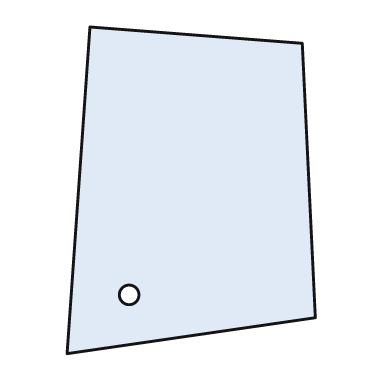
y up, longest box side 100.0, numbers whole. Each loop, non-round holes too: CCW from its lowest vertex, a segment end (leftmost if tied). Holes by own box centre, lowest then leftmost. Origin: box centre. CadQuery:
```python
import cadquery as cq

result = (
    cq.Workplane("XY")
    .moveTo(-38.0, -50.0)
    .lineTo(38.0, -39.0)
    .lineTo(34.0, 45.0)
    .lineTo(-31.0, 50.0)
    .close()
    .moveTo(-19.0, -32.0)
    .circle(3.0)
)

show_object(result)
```